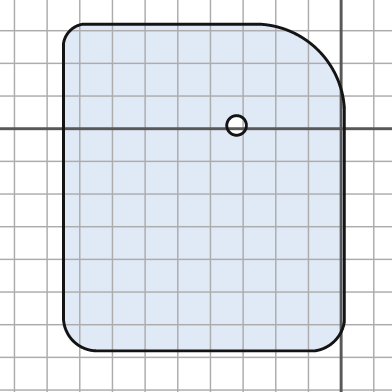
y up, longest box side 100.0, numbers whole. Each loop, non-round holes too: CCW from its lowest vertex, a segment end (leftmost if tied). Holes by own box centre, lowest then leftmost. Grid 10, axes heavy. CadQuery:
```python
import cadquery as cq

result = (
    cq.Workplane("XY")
    .moveTo(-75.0, -68.0)
    .lineTo(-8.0, -68.0)
    .threePointArc((-2.0, -65.0), (1.0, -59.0))
    .lineTo(1.0, 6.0)
    .threePointArc((-7.0, 24.0), (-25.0, 32.0))
    .lineTo(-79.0, 32.0)
    .threePointArc((-83.0, 30.0), (-85.0, 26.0))
    .lineTo(-85.0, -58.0)
    .threePointArc((-82.0, -65.0), (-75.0, -68.0))
    .close()
    .moveTo(-32.0, 1.0)
    .circle(3.0)
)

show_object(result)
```